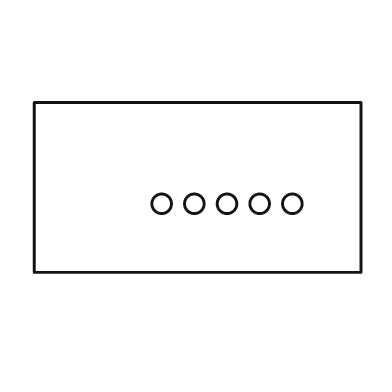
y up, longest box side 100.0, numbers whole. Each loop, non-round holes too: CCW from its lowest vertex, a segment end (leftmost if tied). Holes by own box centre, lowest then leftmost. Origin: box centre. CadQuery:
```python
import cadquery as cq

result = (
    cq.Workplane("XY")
    .moveTo(-50.0, -26.0)
    .lineTo(50.0, -26.0)
    .lineTo(50.0, 26.0)
    .lineTo(-50.0, 26.0)
    .close()
    .moveTo(-11.0, -5.0)
    .circle(3.0)
    .moveTo(-1.0, -5.0)
    .circle(3.0)
    .moveTo(9.0, -5.0)
    .circle(3.0)
    .moveTo(19.0, -5.0)
    .circle(3.0)
    .moveTo(29.0, -5.0)
    .circle(3.0)
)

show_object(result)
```